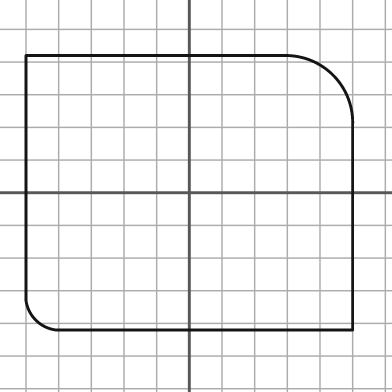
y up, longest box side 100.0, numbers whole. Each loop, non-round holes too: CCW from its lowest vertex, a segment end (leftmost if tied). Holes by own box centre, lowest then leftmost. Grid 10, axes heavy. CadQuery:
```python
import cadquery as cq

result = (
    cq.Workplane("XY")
    .moveTo(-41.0, -42.0)
    .lineTo(50.0, -42.0)
    .lineTo(50.0, 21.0)
    .threePointArc((44.0, 36.0), (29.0, 42.0))
    .lineTo(-50.0, 42.0)
    .lineTo(-50.0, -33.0)
    .threePointArc((-47.0, -39.0), (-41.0, -42.0))
    .close()
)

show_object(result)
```